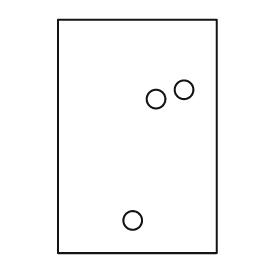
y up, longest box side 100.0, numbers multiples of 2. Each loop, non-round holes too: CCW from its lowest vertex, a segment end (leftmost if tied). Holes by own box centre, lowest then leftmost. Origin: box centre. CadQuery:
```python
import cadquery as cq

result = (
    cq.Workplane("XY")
    .moveTo(-34.0, -50.0)
    .lineTo(34.0, -50.0)
    .lineTo(34.0, 50.0)
    .lineTo(-34.0, 50.0)
    .close()
    .moveTo(-2.0, -36.0)
    .circle(4.0)
    .moveTo(8.0, 16.0)
    .circle(4.0)
    .moveTo(20.0, 20.0)
    .circle(4.0)
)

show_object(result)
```